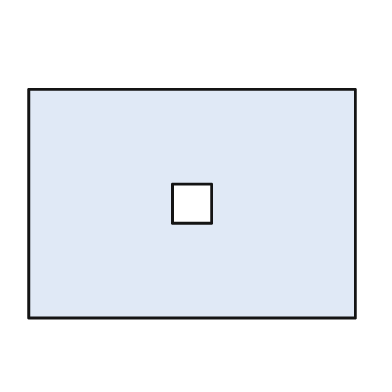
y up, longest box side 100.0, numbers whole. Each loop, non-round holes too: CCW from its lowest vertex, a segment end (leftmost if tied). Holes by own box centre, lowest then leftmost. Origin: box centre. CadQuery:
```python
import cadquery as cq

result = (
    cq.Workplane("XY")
    .moveTo(-50.0, -35.0)
    .lineTo(50.0, -35.0)
    .lineTo(50.0, 35.0)
    .lineTo(-50.0, 35.0)
    .close()
    .moveTo(-6.0, -6.0)
    .lineTo(6.0, -6.0)
    .lineTo(6.0, 6.0)
    .lineTo(-6.0, 6.0)
    .close()
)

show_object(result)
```